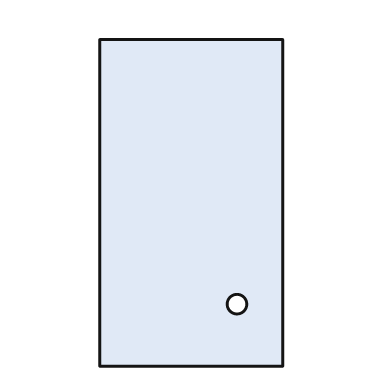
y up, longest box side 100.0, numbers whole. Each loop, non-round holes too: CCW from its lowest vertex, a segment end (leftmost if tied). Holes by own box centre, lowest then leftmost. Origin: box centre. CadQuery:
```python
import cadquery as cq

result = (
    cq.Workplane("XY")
    .moveTo(-28.0, -50.0)
    .lineTo(28.0, -50.0)
    .lineTo(28.0, 50.0)
    .lineTo(-28.0, 50.0)
    .close()
    .moveTo(14.0, -31.0)
    .circle(3.0)
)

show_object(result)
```